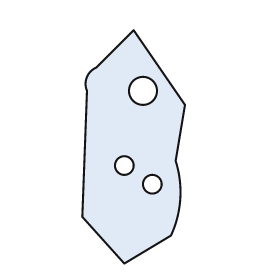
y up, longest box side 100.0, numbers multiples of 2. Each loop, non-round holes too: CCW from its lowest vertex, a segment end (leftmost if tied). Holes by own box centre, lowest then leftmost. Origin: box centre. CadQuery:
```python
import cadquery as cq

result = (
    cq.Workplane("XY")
    .moveTo(-4.0, -50.0)
    .lineTo(16.0, -38.0)
    .threePointArc((20.0, -22.0), (18.0, -6.0))
    .lineTo(22.0, 18.0)
    .lineTo(0.0, 50.0)
    .lineTo(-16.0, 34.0)
    .threePointArc((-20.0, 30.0), (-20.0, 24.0))
    .lineTo(-22.0, -30.0)
    .close()
    .moveTo(8.0, -16.0)
    .circle(4.0)
    .moveTo(-4.0, -8.0)
    .circle(4.0)
    .moveTo(4.0, 24.0)
    .circle(6.0)
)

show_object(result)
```